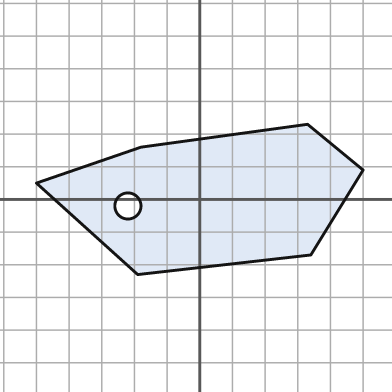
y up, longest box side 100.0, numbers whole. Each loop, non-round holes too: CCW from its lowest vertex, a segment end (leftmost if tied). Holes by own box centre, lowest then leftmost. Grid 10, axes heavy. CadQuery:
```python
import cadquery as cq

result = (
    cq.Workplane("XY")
    .moveTo(-19.0, -23.0)
    .lineTo(34.0, -17.0)
    .lineTo(50.0, 9.0)
    .lineTo(33.0, 23.0)
    .lineTo(-18.0, 16.0)
    .lineTo(-50.0, 5.0)
    .close()
    .moveTo(-22.0, -2.0)
    .circle(4.0)
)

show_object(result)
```